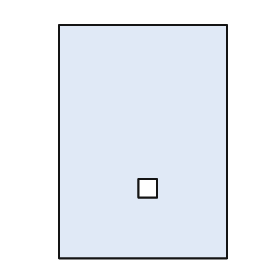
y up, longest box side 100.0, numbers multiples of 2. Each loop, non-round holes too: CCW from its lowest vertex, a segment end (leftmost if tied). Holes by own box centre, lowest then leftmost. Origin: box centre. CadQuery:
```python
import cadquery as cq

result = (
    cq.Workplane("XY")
    .moveTo(-36.0, -50.0)
    .lineTo(36.0, -50.0)
    .lineTo(36.0, 50.0)
    .lineTo(-36.0, 50.0)
    .close()
    .moveTo(-2.0, -24.0)
    .lineTo(6.0, -24.0)
    .lineTo(6.0, -16.0)
    .lineTo(-2.0, -16.0)
    .close()
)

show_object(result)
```